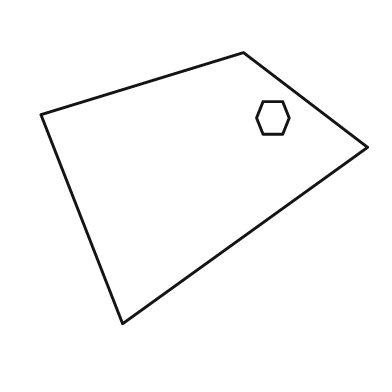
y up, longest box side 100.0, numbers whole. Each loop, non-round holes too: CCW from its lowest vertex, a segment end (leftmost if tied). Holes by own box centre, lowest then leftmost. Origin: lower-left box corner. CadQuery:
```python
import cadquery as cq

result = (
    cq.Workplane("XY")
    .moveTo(25.0, 0.0)
    .lineTo(100.0, 54.0)
    .lineTo(62.0, 83.0)
    .lineTo(0.0, 64.0)
    .close()
    .moveTo(68.0, 58.0)
    .lineTo(74.0, 58.0)
    .lineTo(76.0, 63.0)
    .lineTo(74.0, 68.0)
    .lineTo(68.0, 68.0)
    .lineTo(66.0, 63.0)
    .close()
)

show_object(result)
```